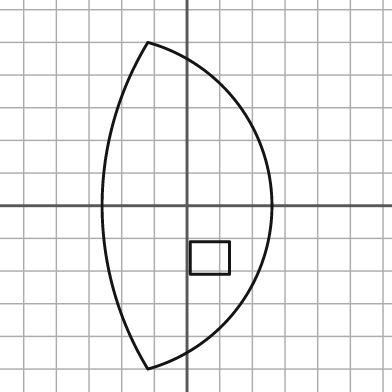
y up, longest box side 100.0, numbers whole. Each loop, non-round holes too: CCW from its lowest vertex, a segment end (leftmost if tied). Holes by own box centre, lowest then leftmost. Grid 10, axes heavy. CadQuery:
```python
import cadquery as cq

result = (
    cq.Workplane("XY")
    .moveTo(-12.0, -50.0)
    .threePointArc((26.0, 0.0), (-12.0, 50.0))
    .threePointArc((-26.0, 0.0), (-12.0, -50.0))
    .close()
    .moveTo(1.0, -21.0)
    .lineTo(13.0, -21.0)
    .lineTo(13.0, -11.0)
    .lineTo(1.0, -11.0)
    .close()
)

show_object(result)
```